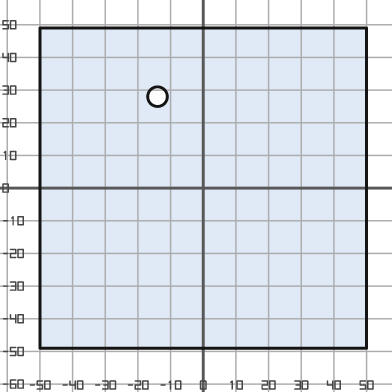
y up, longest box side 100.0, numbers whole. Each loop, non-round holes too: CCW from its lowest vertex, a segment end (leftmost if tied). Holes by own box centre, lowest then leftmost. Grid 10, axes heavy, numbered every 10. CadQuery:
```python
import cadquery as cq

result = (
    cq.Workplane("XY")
    .moveTo(-50.0, -49.0)
    .lineTo(50.0, -49.0)
    .lineTo(50.0, 49.0)
    .lineTo(-50.0, 49.0)
    .close()
    .moveTo(-14.0, 28.0)
    .circle(3.0)
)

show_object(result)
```